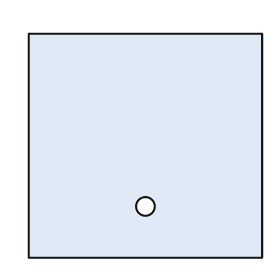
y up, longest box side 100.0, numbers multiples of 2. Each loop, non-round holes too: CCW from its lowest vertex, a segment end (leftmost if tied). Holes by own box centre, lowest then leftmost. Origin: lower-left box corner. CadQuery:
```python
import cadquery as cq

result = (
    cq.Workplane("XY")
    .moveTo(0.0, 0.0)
    .lineTo(100.0, 0.0)
    .lineTo(100.0, 96.0)
    .lineTo(0.0, 96.0)
    .close()
    .moveTo(50.0, 22.0)
    .circle(4.0)
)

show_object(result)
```